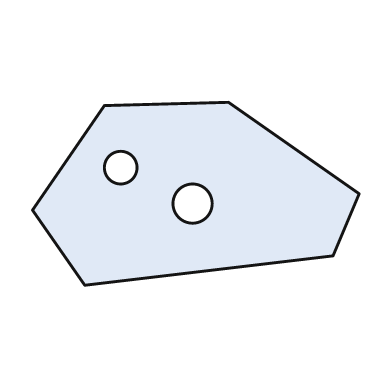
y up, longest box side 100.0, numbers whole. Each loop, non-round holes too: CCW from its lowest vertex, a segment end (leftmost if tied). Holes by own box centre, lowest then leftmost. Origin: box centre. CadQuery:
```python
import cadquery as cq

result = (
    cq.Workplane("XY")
    .moveTo(-34.0, -28.0)
    .lineTo(42.0, -19.0)
    .lineTo(50.0, 0.0)
    .lineTo(10.0, 28.0)
    .lineTo(-28.0, 27.0)
    .lineTo(-50.0, -5.0)
    .close()
    .moveTo(-1.0, -3.0)
    .circle(6.0)
    .moveTo(-23.0, 8.0)
    .circle(5.0)
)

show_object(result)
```